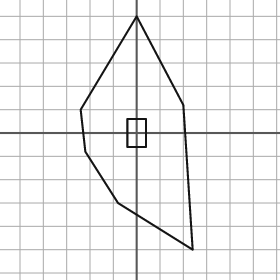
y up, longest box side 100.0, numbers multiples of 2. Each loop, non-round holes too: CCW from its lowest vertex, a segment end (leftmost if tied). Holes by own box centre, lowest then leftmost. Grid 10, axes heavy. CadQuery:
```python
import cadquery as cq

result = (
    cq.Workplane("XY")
    .moveTo(24.0, -50.0)
    .lineTo(20.0, 12.0)
    .lineTo(0.0, 50.0)
    .lineTo(-24.0, 10.0)
    .lineTo(-22.0, -8.0)
    .lineTo(-8.0, -30.0)
    .close()
    .moveTo(-4.0, -6.0)
    .lineTo(4.0, -6.0)
    .lineTo(4.0, 6.0)
    .lineTo(-4.0, 6.0)
    .close()
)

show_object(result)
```